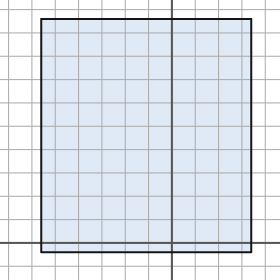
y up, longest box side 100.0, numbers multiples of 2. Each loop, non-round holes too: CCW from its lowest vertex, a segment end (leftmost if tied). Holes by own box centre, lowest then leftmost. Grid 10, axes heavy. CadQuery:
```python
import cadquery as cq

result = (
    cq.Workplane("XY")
    .moveTo(-56.0, -4.0)
    .lineTo(34.0, -4.0)
    .lineTo(34.0, 96.0)
    .lineTo(-56.0, 96.0)
    .close()
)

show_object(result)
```